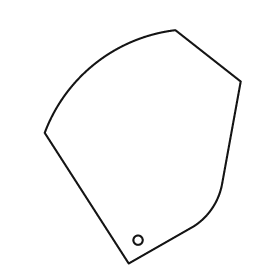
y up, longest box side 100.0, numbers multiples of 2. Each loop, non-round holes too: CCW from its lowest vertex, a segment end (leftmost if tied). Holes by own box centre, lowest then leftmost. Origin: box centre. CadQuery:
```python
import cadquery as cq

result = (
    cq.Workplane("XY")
    .moveTo(-6.0, -50.0)
    .lineTo(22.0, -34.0)
    .threePointArc((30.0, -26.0), (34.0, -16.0))
    .lineTo(42.0, 28.0)
    .lineTo(14.0, 50.0)
    .threePointArc((-20.0, 36.0), (-42.0, 6.0))
    .close()
    .moveTo(-2.0, -40.0)
    .circle(2.0)
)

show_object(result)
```